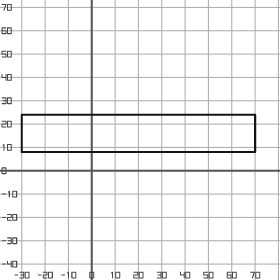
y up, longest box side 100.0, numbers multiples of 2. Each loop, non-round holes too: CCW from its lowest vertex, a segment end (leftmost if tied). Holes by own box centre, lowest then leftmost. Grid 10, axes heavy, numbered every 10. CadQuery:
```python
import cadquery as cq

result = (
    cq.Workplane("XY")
    .moveTo(-30.0, 8.0)
    .lineTo(70.0, 8.0)
    .lineTo(70.0, 24.0)
    .lineTo(-30.0, 24.0)
    .close()
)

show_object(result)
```